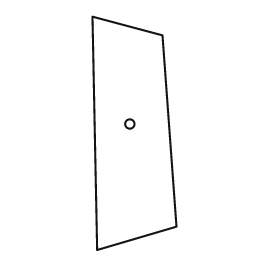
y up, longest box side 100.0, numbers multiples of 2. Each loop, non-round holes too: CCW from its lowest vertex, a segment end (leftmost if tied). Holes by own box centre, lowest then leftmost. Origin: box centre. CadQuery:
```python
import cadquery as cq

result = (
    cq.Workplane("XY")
    .moveTo(-16.0, -50.0)
    .lineTo(18.0, -40.0)
    .lineTo(12.0, 42.0)
    .lineTo(-18.0, 50.0)
    .close()
    .moveTo(-2.0, 4.0)
    .circle(2.0)
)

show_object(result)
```